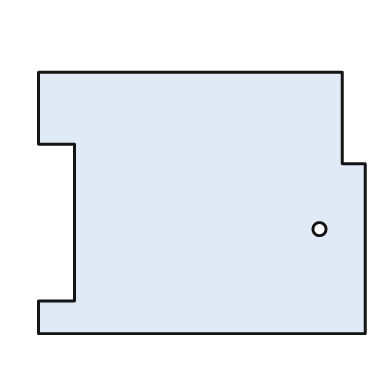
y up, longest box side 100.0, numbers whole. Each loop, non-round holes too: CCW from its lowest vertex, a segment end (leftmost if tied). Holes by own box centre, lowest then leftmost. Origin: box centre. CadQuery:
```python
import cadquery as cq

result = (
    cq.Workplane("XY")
    .moveTo(-50.0, -40.0)
    .lineTo(50.0, -40.0)
    .lineTo(50.0, 12.0)
    .lineTo(43.0, 12.0)
    .lineTo(43.0, 40.0)
    .lineTo(-50.0, 40.0)
    .lineTo(-50.0, 18.0)
    .lineTo(-39.0, 18.0)
    .lineTo(-39.0, -30.0)
    .lineTo(-50.0, -30.0)
    .close()
    .moveTo(36.0, -8.0)
    .circle(2.0)
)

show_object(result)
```